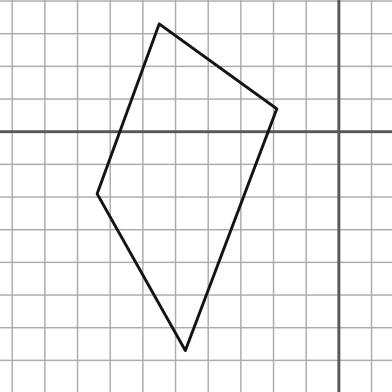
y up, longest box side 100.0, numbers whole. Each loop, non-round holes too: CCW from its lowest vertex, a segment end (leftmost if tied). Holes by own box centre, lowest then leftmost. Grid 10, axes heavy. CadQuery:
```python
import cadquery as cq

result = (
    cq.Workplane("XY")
    .moveTo(-47.0, -67.0)
    .lineTo(-19.0, 7.0)
    .lineTo(-55.0, 33.0)
    .lineTo(-74.0, -19.0)
    .close()
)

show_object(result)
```